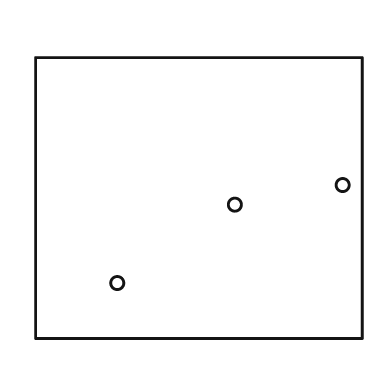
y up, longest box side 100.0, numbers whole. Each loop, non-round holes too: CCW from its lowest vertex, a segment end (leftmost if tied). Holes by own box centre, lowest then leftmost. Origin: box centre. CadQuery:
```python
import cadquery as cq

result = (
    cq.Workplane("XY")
    .moveTo(-50.0, -43.0)
    .lineTo(50.0, -43.0)
    .lineTo(50.0, 43.0)
    .lineTo(-50.0, 43.0)
    .close()
    .moveTo(-25.0, -26.0)
    .circle(2.0)
    .moveTo(11.0, -2.0)
    .circle(2.0)
    .moveTo(44.0, 4.0)
    .circle(2.0)
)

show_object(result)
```